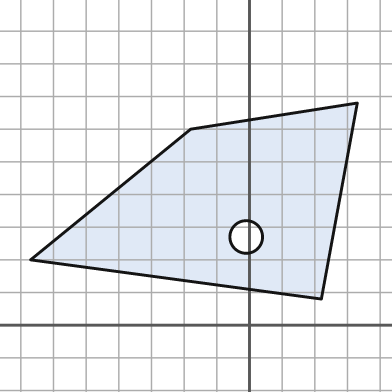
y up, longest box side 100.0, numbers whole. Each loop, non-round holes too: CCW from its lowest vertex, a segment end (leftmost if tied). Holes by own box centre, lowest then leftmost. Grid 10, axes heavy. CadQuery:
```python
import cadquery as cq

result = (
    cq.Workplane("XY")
    .moveTo(22.0, 8.0)
    .lineTo(33.0, 68.0)
    .lineTo(-18.0, 60.0)
    .lineTo(-67.0, 20.0)
    .close()
    .moveTo(-1.0, 27.0)
    .circle(5.0)
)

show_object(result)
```